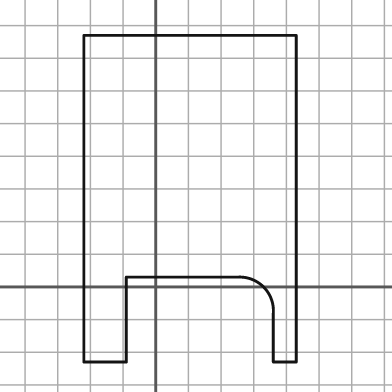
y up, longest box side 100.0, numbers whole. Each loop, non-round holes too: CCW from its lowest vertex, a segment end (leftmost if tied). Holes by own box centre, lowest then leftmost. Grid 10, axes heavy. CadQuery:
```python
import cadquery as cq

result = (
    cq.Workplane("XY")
    .moveTo(-22.0, -23.0)
    .lineTo(-9.0, -23.0)
    .lineTo(-9.0, 3.0)
    .lineTo(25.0, 3.0)
    .threePointArc((33.0, 0.0), (36.0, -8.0))
    .lineTo(36.0, -23.0)
    .lineTo(43.0, -23.0)
    .lineTo(43.0, 77.0)
    .lineTo(-22.0, 77.0)
    .close()
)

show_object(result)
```